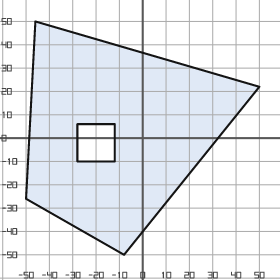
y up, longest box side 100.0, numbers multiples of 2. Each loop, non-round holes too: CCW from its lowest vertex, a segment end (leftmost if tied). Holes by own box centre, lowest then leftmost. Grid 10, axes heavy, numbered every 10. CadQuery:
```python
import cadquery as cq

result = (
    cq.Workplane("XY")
    .moveTo(-8.0, -50.0)
    .lineTo(50.0, 22.0)
    .lineTo(-46.0, 50.0)
    .lineTo(-50.0, -26.0)
    .close()
    .moveTo(-28.0, -10.0)
    .lineTo(-12.0, -10.0)
    .lineTo(-12.0, 6.0)
    .lineTo(-28.0, 6.0)
    .close()
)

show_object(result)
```